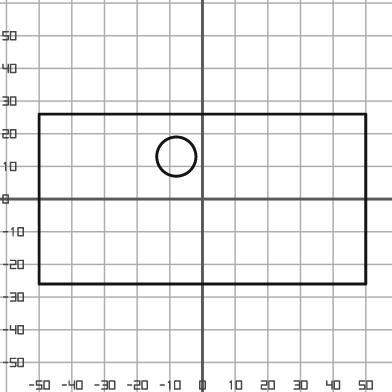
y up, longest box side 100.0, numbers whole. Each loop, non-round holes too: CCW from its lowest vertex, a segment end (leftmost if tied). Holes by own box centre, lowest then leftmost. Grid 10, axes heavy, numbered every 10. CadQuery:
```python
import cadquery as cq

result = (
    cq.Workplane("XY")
    .moveTo(-50.0, -26.0)
    .lineTo(50.0, -26.0)
    .lineTo(50.0, 26.0)
    .lineTo(-50.0, 26.0)
    .close()
    .moveTo(-8.0, 13.0)
    .circle(6.0)
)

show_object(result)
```